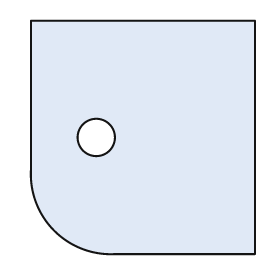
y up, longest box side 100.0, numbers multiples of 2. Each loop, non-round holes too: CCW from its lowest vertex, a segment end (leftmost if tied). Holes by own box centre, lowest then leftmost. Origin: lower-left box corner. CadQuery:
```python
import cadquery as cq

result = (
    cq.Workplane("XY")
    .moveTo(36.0, 0.0)
    .lineTo(96.0, 0.0)
    .lineTo(96.0, 100.0)
    .lineTo(0.0, 100.0)
    .lineTo(0.0, 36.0)
    .threePointArc((10.0, 10.0), (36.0, 0.0))
    .close()
    .moveTo(28.0, 50.0)
    .circle(8.0)
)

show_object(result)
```